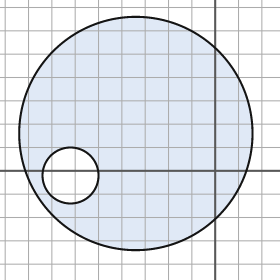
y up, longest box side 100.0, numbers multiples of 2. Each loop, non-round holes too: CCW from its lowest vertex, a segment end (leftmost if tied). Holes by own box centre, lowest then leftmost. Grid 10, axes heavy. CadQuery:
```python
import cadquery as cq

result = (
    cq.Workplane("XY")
    .moveTo(-34.0, 16.0)
    .circle(50.0)
    .moveTo(-62.0, -2.0)
    .circle(12.0)
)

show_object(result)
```